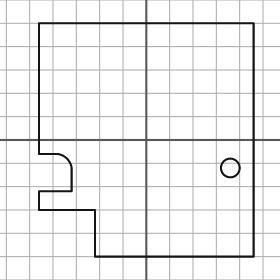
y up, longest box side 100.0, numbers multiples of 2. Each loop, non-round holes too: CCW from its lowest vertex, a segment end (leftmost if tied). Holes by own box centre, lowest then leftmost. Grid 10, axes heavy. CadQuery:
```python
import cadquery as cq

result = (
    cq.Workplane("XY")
    .moveTo(-22.0, -50.0)
    .lineTo(46.0, -50.0)
    .lineTo(46.0, 50.0)
    .lineTo(-46.0, 50.0)
    .lineTo(-46.0, -6.0)
    .lineTo(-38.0, -6.0)
    .threePointArc((-34.0, -8.0), (-32.0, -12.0))
    .lineTo(-32.0, -22.0)
    .lineTo(-46.0, -22.0)
    .lineTo(-46.0, -30.0)
    .lineTo(-22.0, -30.0)
    .close()
    .moveTo(36.0, -12.0)
    .circle(4.0)
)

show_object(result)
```